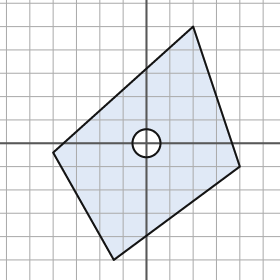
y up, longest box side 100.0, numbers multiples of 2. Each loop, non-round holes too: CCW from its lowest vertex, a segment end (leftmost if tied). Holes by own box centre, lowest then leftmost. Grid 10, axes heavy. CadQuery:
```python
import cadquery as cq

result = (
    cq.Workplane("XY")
    .moveTo(-14.0, -50.0)
    .lineTo(40.0, -10.0)
    .lineTo(20.0, 50.0)
    .lineTo(-40.0, -4.0)
    .close()
    .moveTo(0.0, 0.0)
    .circle(6.0)
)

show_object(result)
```